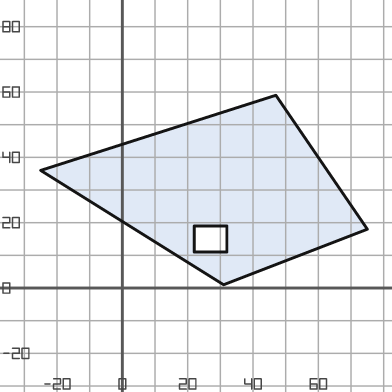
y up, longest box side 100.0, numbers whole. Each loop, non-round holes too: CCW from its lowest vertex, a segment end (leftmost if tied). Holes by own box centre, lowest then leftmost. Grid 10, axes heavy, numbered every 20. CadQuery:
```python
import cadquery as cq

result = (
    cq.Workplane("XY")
    .moveTo(31.0, 1.0)
    .lineTo(75.0, 18.0)
    .lineTo(47.0, 59.0)
    .lineTo(-25.0, 36.0)
    .close()
    .moveTo(22.0, 11.0)
    .lineTo(32.0, 11.0)
    .lineTo(32.0, 19.0)
    .lineTo(22.0, 19.0)
    .close()
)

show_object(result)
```